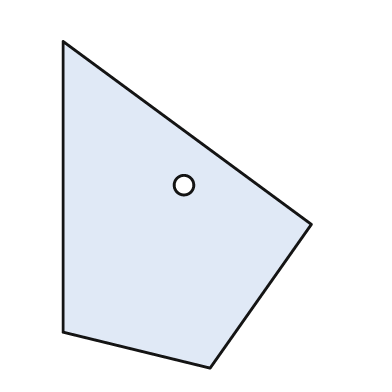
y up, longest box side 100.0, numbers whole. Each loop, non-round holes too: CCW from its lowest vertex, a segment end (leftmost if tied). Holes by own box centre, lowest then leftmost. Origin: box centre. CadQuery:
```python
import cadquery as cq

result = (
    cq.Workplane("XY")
    .moveTo(7.0, -50.0)
    .lineTo(38.0, -6.0)
    .lineTo(-38.0, 50.0)
    .lineTo(-38.0, -39.0)
    .close()
    .moveTo(-1.0, 6.0)
    .circle(3.0)
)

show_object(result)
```